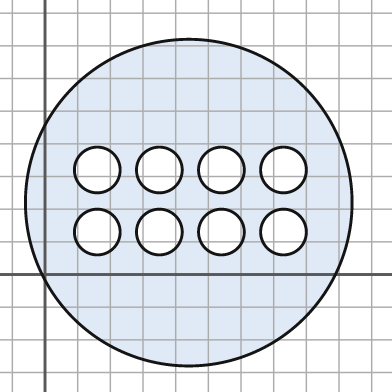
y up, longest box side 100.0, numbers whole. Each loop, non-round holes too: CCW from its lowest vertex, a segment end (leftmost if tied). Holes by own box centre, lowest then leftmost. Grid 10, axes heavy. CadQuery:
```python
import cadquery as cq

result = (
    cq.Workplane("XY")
    .moveTo(44.0, 22.0)
    .circle(50.0)
    .moveTo(16.0, 13.0)
    .circle(7.0)
    .moveTo(35.0, 13.0)
    .circle(7.0)
    .moveTo(54.0, 13.0)
    .circle(7.0)
    .moveTo(73.0, 13.0)
    .circle(7.0)
    .moveTo(16.0, 32.0)
    .circle(7.0)
    .moveTo(35.0, 32.0)
    .circle(7.0)
    .moveTo(54.0, 32.0)
    .circle(7.0)
    .moveTo(73.0, 32.0)
    .circle(7.0)
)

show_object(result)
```